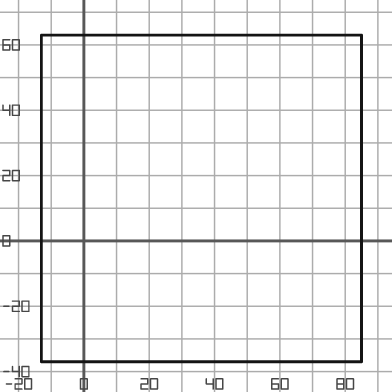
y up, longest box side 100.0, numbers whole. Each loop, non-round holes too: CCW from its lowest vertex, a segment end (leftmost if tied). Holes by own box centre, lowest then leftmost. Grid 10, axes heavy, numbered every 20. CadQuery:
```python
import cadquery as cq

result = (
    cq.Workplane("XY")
    .moveTo(-13.0, -37.0)
    .lineTo(85.0, -37.0)
    .lineTo(85.0, 63.0)
    .lineTo(-13.0, 63.0)
    .close()
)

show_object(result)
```